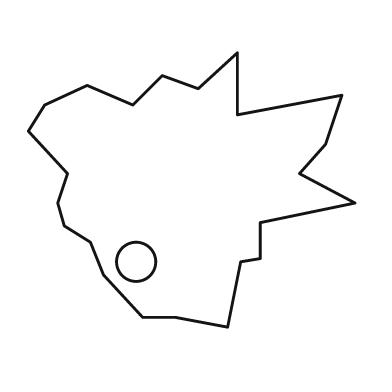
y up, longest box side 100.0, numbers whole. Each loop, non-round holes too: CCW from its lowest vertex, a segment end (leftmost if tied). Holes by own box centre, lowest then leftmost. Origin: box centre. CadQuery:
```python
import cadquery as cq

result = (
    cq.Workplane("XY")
    .moveTo(11.0, -42.0)
    .lineTo(15.0, -22.0)
    .lineTo(21.0, -21.0)
    .lineTo(21.0, -10.0)
    .lineTo(50.0, -4.0)
    .lineTo(33.0, 5.0)
    .lineTo(41.0, 14.0)
    .lineTo(46.0, 29.0)
    .lineTo(14.0, 23.0)
    .lineTo(14.0, 42.0)
    .lineTo(2.0, 31.0)
    .lineTo(-9.0, 35.0)
    .lineTo(-18.0, 26.0)
    .lineTo(-32.0, 32.0)
    .lineTo(-45.0, 26.0)
    .lineTo(-50.0, 18.0)
    .lineTo(-38.0, 5.0)
    .lineTo(-41.0, -4.0)
    .lineTo(-39.0, -11.0)
    .lineTo(-31.0, -16.0)
    .lineTo(-27.0, -26.0)
    .lineTo(-15.0, -39.0)
    .lineTo(-5.0, -39.0)
    .close()
    .moveTo(-17.0, -22.0)
    .circle(6.0)
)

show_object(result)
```